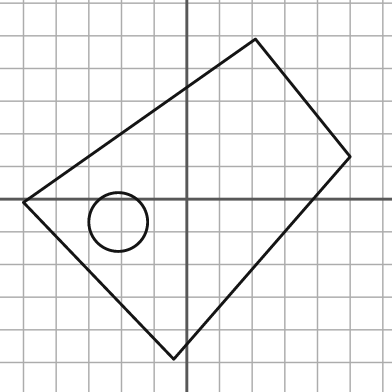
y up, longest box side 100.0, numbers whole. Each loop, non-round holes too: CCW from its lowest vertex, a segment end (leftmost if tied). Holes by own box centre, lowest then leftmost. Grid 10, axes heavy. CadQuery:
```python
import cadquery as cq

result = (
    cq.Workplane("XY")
    .moveTo(-4.0, -49.0)
    .lineTo(50.0, 13.0)
    .lineTo(21.0, 49.0)
    .lineTo(-50.0, -1.0)
    .close()
    .moveTo(-21.0, -7.0)
    .circle(9.0)
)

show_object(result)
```